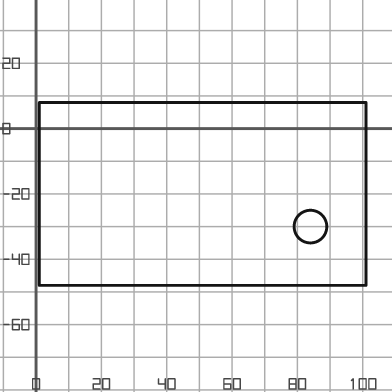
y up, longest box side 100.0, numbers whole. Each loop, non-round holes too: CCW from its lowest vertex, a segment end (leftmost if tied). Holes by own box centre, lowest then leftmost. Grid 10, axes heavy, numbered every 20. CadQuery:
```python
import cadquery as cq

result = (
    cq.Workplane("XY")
    .moveTo(1.0, -48.0)
    .lineTo(101.0, -48.0)
    .lineTo(101.0, 8.0)
    .lineTo(1.0, 8.0)
    .close()
    .moveTo(84.0, -30.0)
    .circle(5.0)
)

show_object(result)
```